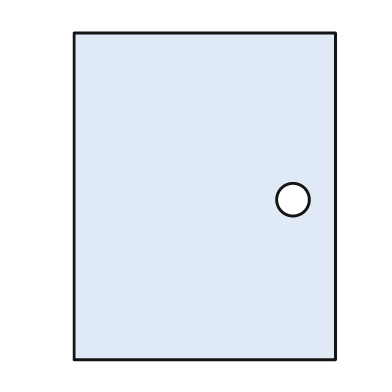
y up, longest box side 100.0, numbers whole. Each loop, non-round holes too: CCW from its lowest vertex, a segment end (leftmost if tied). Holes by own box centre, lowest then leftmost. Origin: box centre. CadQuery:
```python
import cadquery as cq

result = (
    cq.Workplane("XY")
    .moveTo(-40.0, -50.0)
    .lineTo(40.0, -50.0)
    .lineTo(40.0, 50.0)
    .lineTo(-40.0, 50.0)
    .close()
    .moveTo(27.0, -1.0)
    .circle(5.0)
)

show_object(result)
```